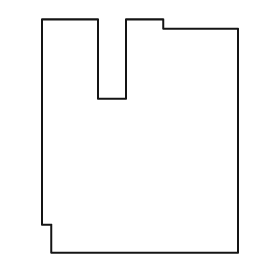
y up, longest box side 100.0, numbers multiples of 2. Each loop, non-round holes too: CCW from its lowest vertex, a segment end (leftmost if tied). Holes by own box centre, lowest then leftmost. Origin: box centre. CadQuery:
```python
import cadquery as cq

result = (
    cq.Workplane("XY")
    .moveTo(-38.0, -50.0)
    .lineTo(42.0, -50.0)
    .lineTo(42.0, 46.0)
    .lineTo(10.0, 46.0)
    .lineTo(10.0, 50.0)
    .lineTo(-6.0, 50.0)
    .lineTo(-6.0, 16.0)
    .lineTo(-18.0, 16.0)
    .lineTo(-18.0, 50.0)
    .lineTo(-42.0, 50.0)
    .lineTo(-42.0, -38.0)
    .lineTo(-38.0, -38.0)
    .close()
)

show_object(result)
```